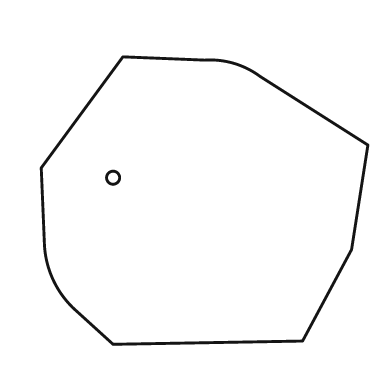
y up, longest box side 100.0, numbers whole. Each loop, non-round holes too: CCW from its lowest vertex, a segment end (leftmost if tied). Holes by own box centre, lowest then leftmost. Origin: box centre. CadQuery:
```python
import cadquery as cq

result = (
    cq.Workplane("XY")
    .moveTo(-28.0, -44.0)
    .lineTo(30.0, -43.0)
    .lineTo(45.0, -15.0)
    .lineTo(50.0, 17.0)
    .lineTo(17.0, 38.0)
    .threePointArc((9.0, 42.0), (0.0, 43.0))
    .lineTo(-25.0, 44.0)
    .lineTo(-50.0, 10.0)
    .lineTo(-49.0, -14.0)
    .threePointArc((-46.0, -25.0), (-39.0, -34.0))
    .close()
    .moveTo(-28.0, 7.0)
    .circle(2.0)
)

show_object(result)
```